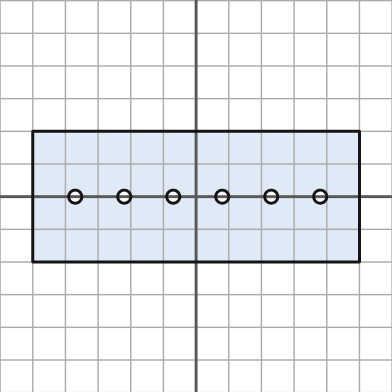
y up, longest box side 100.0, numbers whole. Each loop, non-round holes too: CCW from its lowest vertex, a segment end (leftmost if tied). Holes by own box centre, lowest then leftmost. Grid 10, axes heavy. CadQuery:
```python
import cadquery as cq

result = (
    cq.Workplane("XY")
    .moveTo(-50.0, -20.0)
    .lineTo(50.0, -20.0)
    .lineTo(50.0, 20.0)
    .lineTo(-50.0, 20.0)
    .close()
    .moveTo(-37.0, 0.0)
    .circle(2.0)
    .moveTo(-22.0, 0.0)
    .circle(2.0)
    .moveTo(-7.0, 0.0)
    .circle(2.0)
    .moveTo(8.0, 0.0)
    .circle(2.0)
    .moveTo(23.0, 0.0)
    .circle(2.0)
    .moveTo(38.0, 0.0)
    .circle(2.0)
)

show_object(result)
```